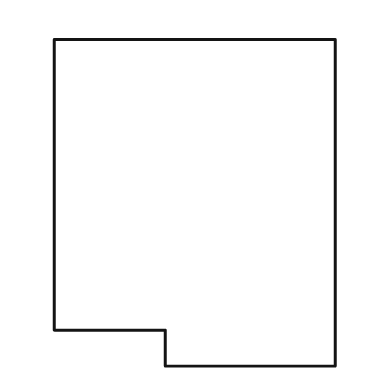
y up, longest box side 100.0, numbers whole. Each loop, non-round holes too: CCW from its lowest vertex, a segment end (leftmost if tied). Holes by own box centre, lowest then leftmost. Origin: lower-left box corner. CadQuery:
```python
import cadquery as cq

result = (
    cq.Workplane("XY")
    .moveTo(34.0, 0.0)
    .lineTo(86.0, 0.0)
    .lineTo(86.0, 100.0)
    .lineTo(0.0, 100.0)
    .lineTo(0.0, 11.0)
    .lineTo(34.0, 11.0)
    .close()
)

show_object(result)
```